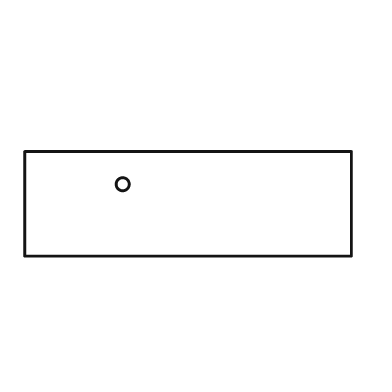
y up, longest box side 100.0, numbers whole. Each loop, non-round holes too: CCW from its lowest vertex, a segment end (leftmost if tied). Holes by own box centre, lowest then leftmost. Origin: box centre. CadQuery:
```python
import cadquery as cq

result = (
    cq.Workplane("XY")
    .moveTo(-50.0, -16.0)
    .lineTo(50.0, -16.0)
    .lineTo(50.0, 16.0)
    .lineTo(-50.0, 16.0)
    .close()
    .moveTo(-20.0, 6.0)
    .circle(2.0)
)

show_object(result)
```